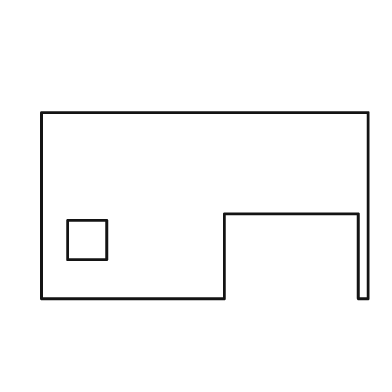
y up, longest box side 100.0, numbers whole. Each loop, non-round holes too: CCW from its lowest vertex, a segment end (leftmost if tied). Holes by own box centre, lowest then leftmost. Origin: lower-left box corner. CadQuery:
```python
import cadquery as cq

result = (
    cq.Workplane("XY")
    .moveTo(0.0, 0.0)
    .lineTo(56.0, 0.0)
    .lineTo(56.0, 26.0)
    .lineTo(97.0, 26.0)
    .lineTo(97.0, 0.0)
    .lineTo(100.0, 0.0)
    .lineTo(100.0, 57.0)
    .lineTo(0.0, 57.0)
    .close()
    .moveTo(8.0, 12.0)
    .lineTo(20.0, 12.0)
    .lineTo(20.0, 24.0)
    .lineTo(8.0, 24.0)
    .close()
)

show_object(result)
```